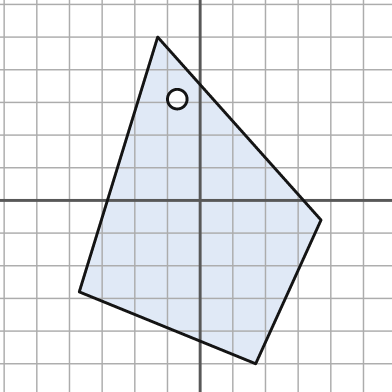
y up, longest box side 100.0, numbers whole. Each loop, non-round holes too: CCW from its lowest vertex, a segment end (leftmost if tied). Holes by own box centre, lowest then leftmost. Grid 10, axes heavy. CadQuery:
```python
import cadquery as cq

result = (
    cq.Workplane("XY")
    .moveTo(17.0, -50.0)
    .lineTo(37.0, -6.0)
    .lineTo(-13.0, 50.0)
    .lineTo(-37.0, -28.0)
    .close()
    .moveTo(-7.0, 31.0)
    .circle(3.0)
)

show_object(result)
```